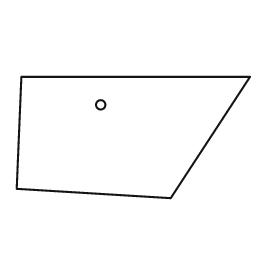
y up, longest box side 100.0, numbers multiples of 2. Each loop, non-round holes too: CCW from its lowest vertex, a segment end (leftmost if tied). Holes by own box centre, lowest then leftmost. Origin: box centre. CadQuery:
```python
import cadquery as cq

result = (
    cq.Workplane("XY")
    .moveTo(16.0, -26.0)
    .lineTo(50.0, 26.0)
    .lineTo(-48.0, 26.0)
    .lineTo(-50.0, -22.0)
    .close()
    .moveTo(-14.0, 14.0)
    .circle(2.0)
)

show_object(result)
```